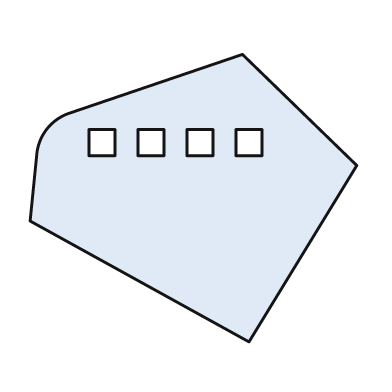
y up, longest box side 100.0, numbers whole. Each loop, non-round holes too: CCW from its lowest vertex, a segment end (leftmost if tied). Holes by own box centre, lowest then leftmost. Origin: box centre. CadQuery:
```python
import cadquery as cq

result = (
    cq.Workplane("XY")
    .moveTo(17.0, -44.0)
    .lineTo(50.0, 10.0)
    .lineTo(15.0, 44.0)
    .lineTo(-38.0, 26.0)
    .threePointArc((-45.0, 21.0), (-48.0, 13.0))
    .lineTo(-50.0, -7.0)
    .close()
    .moveTo(-32.0, 13.0)
    .lineTo(-24.0, 13.0)
    .lineTo(-24.0, 21.0)
    .lineTo(-32.0, 21.0)
    .close()
    .moveTo(-17.0, 13.0)
    .lineTo(-9.0, 13.0)
    .lineTo(-9.0, 21.0)
    .lineTo(-17.0, 21.0)
    .close()
    .moveTo(-2.0, 13.0)
    .lineTo(6.0, 13.0)
    .lineTo(6.0, 21.0)
    .lineTo(-2.0, 21.0)
    .close()
    .moveTo(13.0, 13.0)
    .lineTo(21.0, 13.0)
    .lineTo(21.0, 21.0)
    .lineTo(13.0, 21.0)
    .close()
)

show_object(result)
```